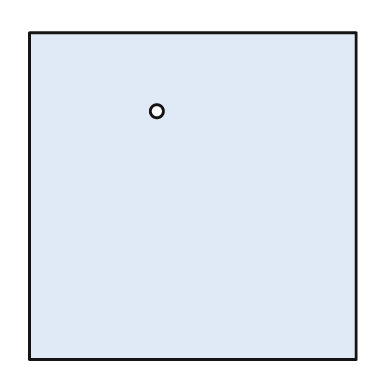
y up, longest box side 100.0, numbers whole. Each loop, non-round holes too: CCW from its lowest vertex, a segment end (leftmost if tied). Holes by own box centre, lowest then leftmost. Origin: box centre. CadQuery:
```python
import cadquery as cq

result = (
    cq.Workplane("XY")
    .moveTo(-50.0, -50.0)
    .lineTo(50.0, -50.0)
    .lineTo(50.0, 50.0)
    .lineTo(-50.0, 50.0)
    .close()
    .moveTo(-11.0, 26.0)
    .circle(2.0)
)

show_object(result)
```